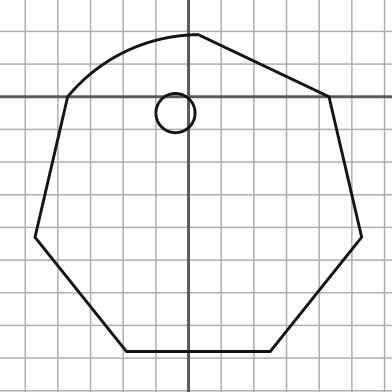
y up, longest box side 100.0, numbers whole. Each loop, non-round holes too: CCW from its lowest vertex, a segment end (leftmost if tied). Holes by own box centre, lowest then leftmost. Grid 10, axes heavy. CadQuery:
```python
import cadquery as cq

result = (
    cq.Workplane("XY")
    .moveTo(-19.0, -78.0)
    .lineTo(25.0, -78.0)
    .lineTo(53.0, -43.0)
    .lineTo(43.0, 0.0)
    .lineTo(3.0, 19.0)
    .threePointArc((-19.0, 14.0), (-37.0, 0.0))
    .lineTo(-47.0, -43.0)
    .close()
    .moveTo(-4.0, -5.0)
    .circle(6.0)
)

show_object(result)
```